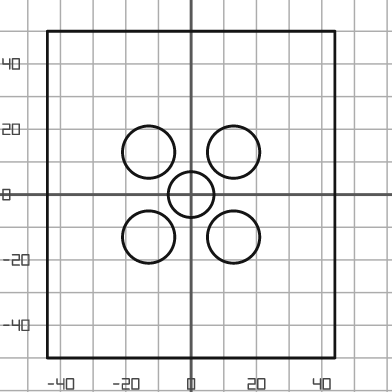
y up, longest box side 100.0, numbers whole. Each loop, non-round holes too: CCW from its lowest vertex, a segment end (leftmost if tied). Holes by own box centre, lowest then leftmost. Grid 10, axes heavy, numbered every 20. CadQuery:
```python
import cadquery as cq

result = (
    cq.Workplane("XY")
    .moveTo(-44.0, -50.0)
    .lineTo(44.0, -50.0)
    .lineTo(44.0, 50.0)
    .lineTo(-44.0, 50.0)
    .close()
    .moveTo(-13.0, -13.0)
    .circle(8.0)
    .moveTo(13.0, -13.0)
    .circle(8.0)
    .moveTo(0.0, 0.0)
    .circle(7.0)
    .moveTo(-13.0, 13.0)
    .circle(8.0)
    .moveTo(13.0, 13.0)
    .circle(8.0)
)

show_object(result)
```